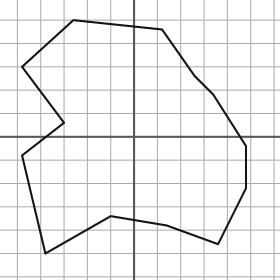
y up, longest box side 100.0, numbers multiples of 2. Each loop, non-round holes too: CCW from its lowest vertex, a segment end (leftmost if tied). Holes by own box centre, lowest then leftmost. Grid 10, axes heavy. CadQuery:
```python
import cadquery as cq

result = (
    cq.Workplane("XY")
    .moveTo(-38.0, -50.0)
    .lineTo(-10.0, -34.0)
    .lineTo(14.0, -38.0)
    .lineTo(36.0, -46.0)
    .lineTo(48.0, -22.0)
    .lineTo(48.0, -4.0)
    .lineTo(34.0, 18.0)
    .lineTo(26.0, 26.0)
    .lineTo(12.0, 46.0)
    .lineTo(-26.0, 50.0)
    .lineTo(-48.0, 30.0)
    .lineTo(-30.0, 6.0)
    .lineTo(-48.0, -8.0)
    .close()
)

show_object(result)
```